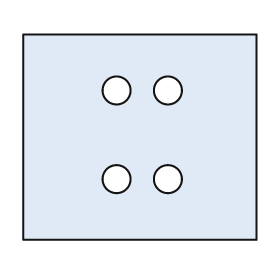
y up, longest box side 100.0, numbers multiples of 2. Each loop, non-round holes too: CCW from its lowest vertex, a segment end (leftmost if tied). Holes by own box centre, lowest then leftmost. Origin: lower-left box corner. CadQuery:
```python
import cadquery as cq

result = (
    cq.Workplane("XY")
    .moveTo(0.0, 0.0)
    .lineTo(100.0, 0.0)
    .lineTo(100.0, 88.0)
    .lineTo(0.0, 88.0)
    .close()
    .moveTo(40.0, 26.0)
    .circle(6.0)
    .moveTo(62.0, 26.0)
    .circle(6.0)
    .moveTo(40.0, 64.0)
    .circle(6.0)
    .moveTo(62.0, 64.0)
    .circle(6.0)
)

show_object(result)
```